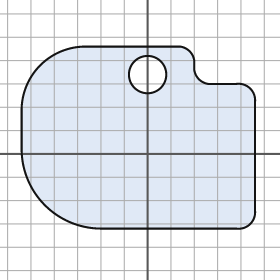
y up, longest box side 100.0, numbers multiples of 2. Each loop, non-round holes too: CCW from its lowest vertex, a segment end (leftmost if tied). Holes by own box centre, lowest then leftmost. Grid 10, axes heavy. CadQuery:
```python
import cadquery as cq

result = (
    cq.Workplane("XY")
    .moveTo(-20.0, -32.0)
    .lineTo(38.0, -32.0)
    .threePointArc((44.0, -30.0), (46.0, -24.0))
    .lineTo(46.0, 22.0)
    .threePointArc((44.0, 28.0), (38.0, 30.0))
    .lineTo(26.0, 30.0)
    .threePointArc((22.0, 32.0), (20.0, 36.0))
    .lineTo(20.0, 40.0)
    .threePointArc((18.0, 44.0), (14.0, 46.0))
    .lineTo(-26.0, 46.0)
    .threePointArc((-46.0, 38.0), (-54.0, 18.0))
    .lineTo(-54.0, 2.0)
    .threePointArc((-44.0, -22.0), (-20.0, -32.0))
    .close()
    .moveTo(0.0, 34.0)
    .circle(8.0)
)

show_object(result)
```